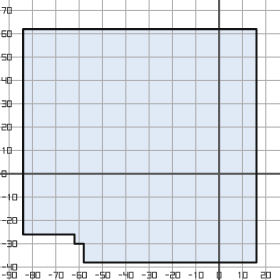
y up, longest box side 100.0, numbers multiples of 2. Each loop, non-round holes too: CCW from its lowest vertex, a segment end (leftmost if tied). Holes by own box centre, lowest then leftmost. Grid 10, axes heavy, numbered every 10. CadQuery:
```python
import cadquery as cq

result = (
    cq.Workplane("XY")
    .moveTo(-58.0, -38.0)
    .lineTo(16.0, -38.0)
    .lineTo(16.0, 62.0)
    .lineTo(-84.0, 62.0)
    .lineTo(-84.0, -26.0)
    .lineTo(-62.0, -26.0)
    .lineTo(-62.0, -30.0)
    .lineTo(-58.0, -30.0)
    .close()
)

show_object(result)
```